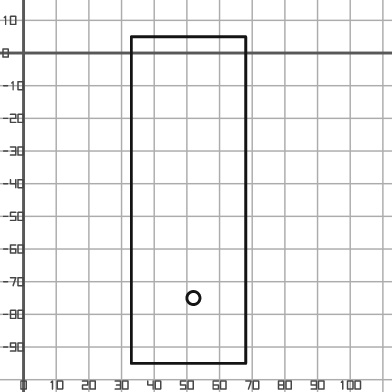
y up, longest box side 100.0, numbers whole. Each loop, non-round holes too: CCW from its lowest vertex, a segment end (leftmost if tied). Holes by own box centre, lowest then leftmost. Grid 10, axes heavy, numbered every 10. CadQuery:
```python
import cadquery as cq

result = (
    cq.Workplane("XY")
    .moveTo(33.0, -95.0)
    .lineTo(68.0, -95.0)
    .lineTo(68.0, 5.0)
    .lineTo(33.0, 5.0)
    .close()
    .moveTo(52.0, -75.0)
    .circle(2.0)
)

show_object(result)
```